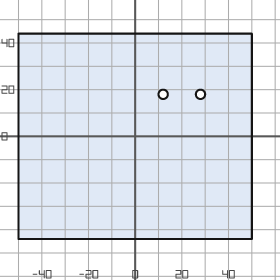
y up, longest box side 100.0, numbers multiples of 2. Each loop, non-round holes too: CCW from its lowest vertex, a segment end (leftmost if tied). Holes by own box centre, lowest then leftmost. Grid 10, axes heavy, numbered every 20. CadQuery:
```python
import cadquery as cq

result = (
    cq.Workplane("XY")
    .moveTo(-50.0, -44.0)
    .lineTo(50.0, -44.0)
    .lineTo(50.0, 44.0)
    .lineTo(-50.0, 44.0)
    .close()
    .moveTo(12.0, 18.0)
    .circle(2.0)
    .moveTo(28.0, 18.0)
    .circle(2.0)
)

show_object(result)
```